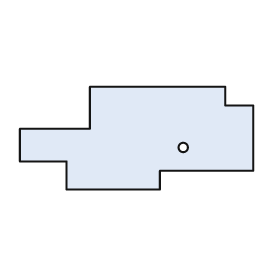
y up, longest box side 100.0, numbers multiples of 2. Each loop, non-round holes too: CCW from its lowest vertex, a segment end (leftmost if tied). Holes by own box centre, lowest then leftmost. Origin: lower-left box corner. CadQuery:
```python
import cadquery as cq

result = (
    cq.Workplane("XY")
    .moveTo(20.0, 0.0)
    .lineTo(60.0, 0.0)
    .lineTo(60.0, 8.0)
    .lineTo(100.0, 8.0)
    .lineTo(100.0, 36.0)
    .lineTo(88.0, 36.0)
    .lineTo(88.0, 44.0)
    .lineTo(30.0, 44.0)
    .lineTo(30.0, 26.0)
    .lineTo(0.0, 26.0)
    .lineTo(0.0, 12.0)
    .lineTo(20.0, 12.0)
    .close()
    .moveTo(70.0, 18.0)
    .circle(2.0)
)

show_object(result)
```